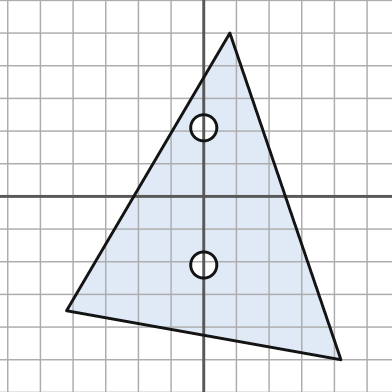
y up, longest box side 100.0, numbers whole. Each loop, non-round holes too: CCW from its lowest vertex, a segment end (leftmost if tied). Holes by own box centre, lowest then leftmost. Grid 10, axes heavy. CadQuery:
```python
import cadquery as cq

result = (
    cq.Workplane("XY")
    .moveTo(42.0, -50.0)
    .lineTo(8.0, 50.0)
    .lineTo(-42.0, -35.0)
    .close()
    .moveTo(0.0, -21.0)
    .circle(4.0)
    .moveTo(0.0, 21.0)
    .circle(4.0)
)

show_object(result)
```